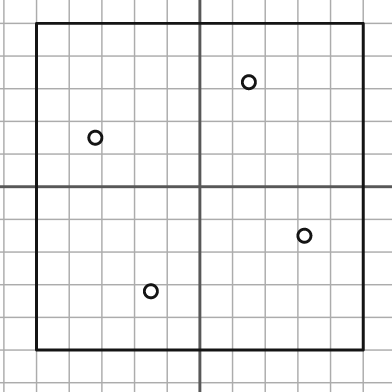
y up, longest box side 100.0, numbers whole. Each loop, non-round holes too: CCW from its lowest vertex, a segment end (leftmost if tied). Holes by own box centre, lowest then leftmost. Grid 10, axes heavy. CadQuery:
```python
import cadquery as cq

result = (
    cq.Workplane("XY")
    .moveTo(-50.0, -50.0)
    .lineTo(50.0, -50.0)
    .lineTo(50.0, 50.0)
    .lineTo(-50.0, 50.0)
    .close()
    .moveTo(-15.0, -32.0)
    .circle(2.0)
    .moveTo(32.0, -15.0)
    .circle(2.0)
    .moveTo(-32.0, 15.0)
    .circle(2.0)
    .moveTo(15.0, 32.0)
    .circle(2.0)
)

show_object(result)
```